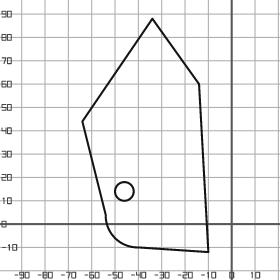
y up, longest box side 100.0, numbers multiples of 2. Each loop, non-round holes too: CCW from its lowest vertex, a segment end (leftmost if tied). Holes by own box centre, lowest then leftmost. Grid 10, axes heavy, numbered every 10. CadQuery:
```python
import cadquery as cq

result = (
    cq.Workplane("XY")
    .moveTo(-10.0, -12.0)
    .lineTo(-14.0, 60.0)
    .lineTo(-34.0, 88.0)
    .lineTo(-64.0, 44.0)
    .lineTo(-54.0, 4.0)
    .threePointArc((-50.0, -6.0), (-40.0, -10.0))
    .close()
    .moveTo(-46.0, 14.0)
    .circle(4.0)
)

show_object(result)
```